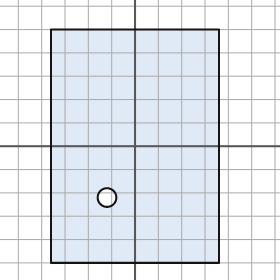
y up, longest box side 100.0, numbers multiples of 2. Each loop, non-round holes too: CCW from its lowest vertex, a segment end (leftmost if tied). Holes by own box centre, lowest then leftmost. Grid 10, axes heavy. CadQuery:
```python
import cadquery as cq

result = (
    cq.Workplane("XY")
    .moveTo(-36.0, -50.0)
    .lineTo(36.0, -50.0)
    .lineTo(36.0, 50.0)
    .lineTo(-36.0, 50.0)
    .close()
    .moveTo(-12.0, -22.0)
    .circle(4.0)
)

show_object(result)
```